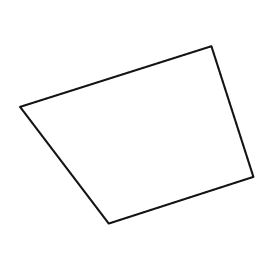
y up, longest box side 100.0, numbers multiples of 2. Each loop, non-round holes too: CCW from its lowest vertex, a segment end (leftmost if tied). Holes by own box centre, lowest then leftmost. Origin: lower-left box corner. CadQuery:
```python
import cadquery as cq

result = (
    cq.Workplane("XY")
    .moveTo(38.0, 0.0)
    .lineTo(100.0, 20.0)
    .lineTo(82.0, 76.0)
    .lineTo(0.0, 50.0)
    .close()
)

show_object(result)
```